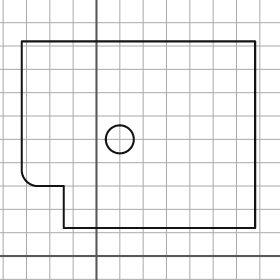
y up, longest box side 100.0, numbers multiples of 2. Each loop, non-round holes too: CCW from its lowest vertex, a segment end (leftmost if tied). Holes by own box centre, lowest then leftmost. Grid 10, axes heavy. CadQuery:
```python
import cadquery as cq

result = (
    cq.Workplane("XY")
    .moveTo(-14.0, 12.0)
    .lineTo(68.0, 12.0)
    .lineTo(68.0, 92.0)
    .lineTo(-32.0, 92.0)
    .lineTo(-32.0, 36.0)
    .threePointArc((-30.0, 32.0), (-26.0, 30.0))
    .lineTo(-14.0, 30.0)
    .close()
    .moveTo(10.0, 50.0)
    .circle(6.0)
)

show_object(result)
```